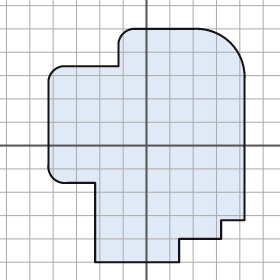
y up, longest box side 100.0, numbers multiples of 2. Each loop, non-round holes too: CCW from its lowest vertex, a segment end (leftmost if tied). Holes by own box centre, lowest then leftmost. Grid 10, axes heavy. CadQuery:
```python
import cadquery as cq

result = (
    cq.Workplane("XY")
    .moveTo(-22.0, -50.0)
    .lineTo(14.0, -50.0)
    .lineTo(14.0, -40.0)
    .lineTo(32.0, -40.0)
    .lineTo(32.0, -32.0)
    .lineTo(42.0, -32.0)
    .lineTo(42.0, 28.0)
    .threePointArc((36.0, 44.0), (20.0, 50.0))
    .lineTo(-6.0, 50.0)
    .threePointArc((-10.0, 48.0), (-12.0, 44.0))
    .lineTo(-12.0, 34.0)
    .lineTo(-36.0, 34.0)
    .threePointArc((-40.0, 32.0), (-42.0, 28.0))
    .lineTo(-42.0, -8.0)
    .threePointArc((-40.0, -14.0), (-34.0, -16.0))
    .lineTo(-22.0, -16.0)
    .close()
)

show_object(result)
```